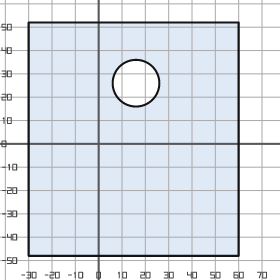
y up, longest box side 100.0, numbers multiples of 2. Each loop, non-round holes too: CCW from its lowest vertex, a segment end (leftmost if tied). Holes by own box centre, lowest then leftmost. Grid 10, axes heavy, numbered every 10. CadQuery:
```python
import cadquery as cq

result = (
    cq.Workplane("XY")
    .moveTo(-30.0, -48.0)
    .lineTo(60.0, -48.0)
    .lineTo(60.0, 52.0)
    .lineTo(-30.0, 52.0)
    .close()
    .moveTo(16.0, 26.0)
    .circle(10.0)
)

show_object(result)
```